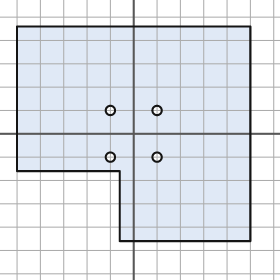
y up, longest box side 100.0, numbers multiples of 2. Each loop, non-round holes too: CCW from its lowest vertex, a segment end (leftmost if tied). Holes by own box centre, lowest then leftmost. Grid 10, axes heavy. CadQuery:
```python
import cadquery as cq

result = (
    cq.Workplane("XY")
    .moveTo(-6.0, -46.0)
    .lineTo(50.0, -46.0)
    .lineTo(50.0, 46.0)
    .lineTo(-50.0, 46.0)
    .lineTo(-50.0, -16.0)
    .lineTo(-6.0, -16.0)
    .close()
    .moveTo(-10.0, -10.0)
    .circle(2.0)
    .moveTo(10.0, -10.0)
    .circle(2.0)
    .moveTo(-10.0, 10.0)
    .circle(2.0)
    .moveTo(10.0, 10.0)
    .circle(2.0)
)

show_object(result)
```